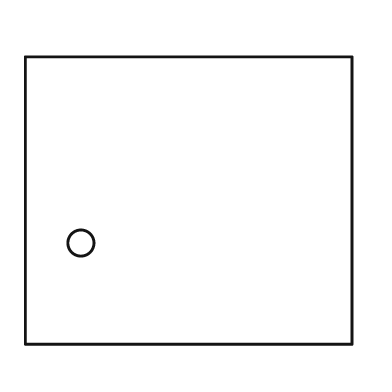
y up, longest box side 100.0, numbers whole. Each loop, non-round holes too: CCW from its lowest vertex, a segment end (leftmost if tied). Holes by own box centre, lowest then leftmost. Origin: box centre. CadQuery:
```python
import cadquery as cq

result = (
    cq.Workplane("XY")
    .moveTo(-50.0, -44.0)
    .lineTo(50.0, -44.0)
    .lineTo(50.0, 44.0)
    .lineTo(-50.0, 44.0)
    .close()
    .moveTo(-33.0, -13.0)
    .circle(4.0)
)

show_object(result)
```